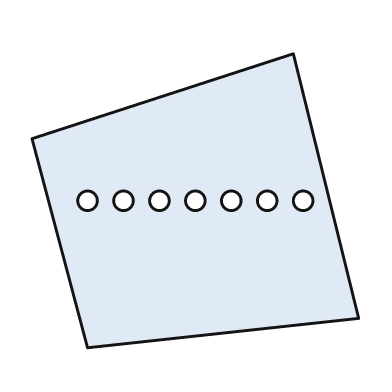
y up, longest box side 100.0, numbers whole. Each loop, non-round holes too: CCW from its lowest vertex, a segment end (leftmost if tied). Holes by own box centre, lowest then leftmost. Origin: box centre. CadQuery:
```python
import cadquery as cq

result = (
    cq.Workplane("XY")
    .moveTo(-33.0, -45.0)
    .lineTo(50.0, -36.0)
    .lineTo(30.0, 45.0)
    .lineTo(-50.0, 19.0)
    .close()
    .moveTo(-33.0, 0.0)
    .circle(3.0)
    .moveTo(-22.0, 0.0)
    .circle(3.0)
    .moveTo(-11.0, 0.0)
    .circle(3.0)
    .moveTo(0.0, 0.0)
    .circle(3.0)
    .moveTo(11.0, 0.0)
    .circle(3.0)
    .moveTo(22.0, 0.0)
    .circle(3.0)
    .moveTo(33.0, 0.0)
    .circle(3.0)
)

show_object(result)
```